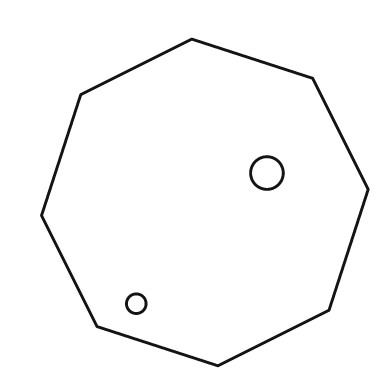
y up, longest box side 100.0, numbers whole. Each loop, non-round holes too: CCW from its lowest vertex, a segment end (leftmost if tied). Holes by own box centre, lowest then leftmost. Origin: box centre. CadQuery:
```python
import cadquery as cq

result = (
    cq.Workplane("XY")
    .moveTo(4.0, -50.0)
    .lineTo(38.0, -33.0)
    .lineTo(50.0, 4.0)
    .lineTo(33.0, 38.0)
    .lineTo(-4.0, 50.0)
    .lineTo(-38.0, 33.0)
    .lineTo(-50.0, -4.0)
    .lineTo(-33.0, -38.0)
    .close()
    .moveTo(-21.0, -31.0)
    .circle(3.0)
    .moveTo(19.0, 9.0)
    .circle(5.0)
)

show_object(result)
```